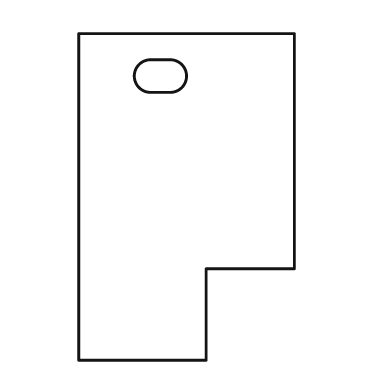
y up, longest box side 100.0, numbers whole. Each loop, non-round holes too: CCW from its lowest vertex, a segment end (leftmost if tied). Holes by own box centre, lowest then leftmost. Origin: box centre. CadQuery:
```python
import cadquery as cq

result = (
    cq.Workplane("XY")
    .moveTo(-33.0, -50.0)
    .lineTo(6.0, -50.0)
    .lineTo(6.0, -22.0)
    .lineTo(33.0, -22.0)
    .lineTo(33.0, 50.0)
    .lineTo(-33.0, 50.0)
    .close()
    .moveTo(-11.0, 32.0)
    .lineTo(-5.0, 32.0)
    .threePointArc((0.0, 37.0), (-5.0, 42.0))
    .lineTo(-11.0, 42.0)
    .threePointArc((-16.0, 37.0), (-11.0, 32.0))
    .close()
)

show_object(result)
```